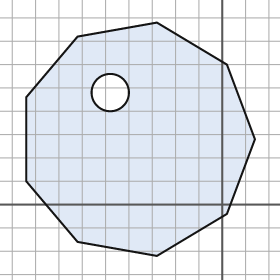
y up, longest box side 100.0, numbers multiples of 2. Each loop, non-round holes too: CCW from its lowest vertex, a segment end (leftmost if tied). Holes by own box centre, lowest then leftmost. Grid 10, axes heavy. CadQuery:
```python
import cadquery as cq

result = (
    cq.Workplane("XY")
    .moveTo(-28.0, -22.0)
    .lineTo(2.0, -4.0)
    .lineTo(14.0, 28.0)
    .lineTo(2.0, 60.0)
    .lineTo(-28.0, 78.0)
    .lineTo(-62.0, 72.0)
    .lineTo(-84.0, 46.0)
    .lineTo(-84.0, 10.0)
    .lineTo(-62.0, -16.0)
    .close()
    .moveTo(-48.0, 48.0)
    .circle(8.0)
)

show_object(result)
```